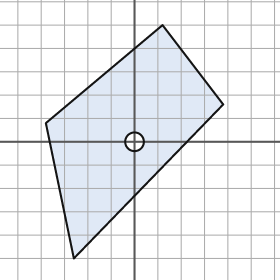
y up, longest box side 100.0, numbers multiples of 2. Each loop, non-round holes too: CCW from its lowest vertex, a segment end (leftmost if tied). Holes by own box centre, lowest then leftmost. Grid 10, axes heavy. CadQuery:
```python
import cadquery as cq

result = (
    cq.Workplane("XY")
    .moveTo(-26.0, -50.0)
    .lineTo(38.0, 16.0)
    .lineTo(12.0, 50.0)
    .lineTo(-38.0, 8.0)
    .close()
    .moveTo(0.0, 0.0)
    .circle(4.0)
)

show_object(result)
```